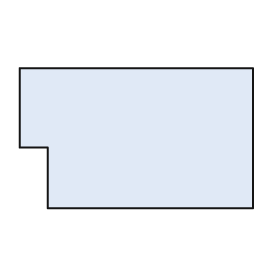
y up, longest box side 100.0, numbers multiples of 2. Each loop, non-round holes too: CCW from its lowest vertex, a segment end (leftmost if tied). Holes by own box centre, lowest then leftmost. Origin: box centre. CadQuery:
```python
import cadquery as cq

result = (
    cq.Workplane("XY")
    .moveTo(-38.0, -30.0)
    .lineTo(50.0, -30.0)
    .lineTo(50.0, 30.0)
    .lineTo(-50.0, 30.0)
    .lineTo(-50.0, -4.0)
    .lineTo(-38.0, -4.0)
    .close()
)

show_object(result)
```